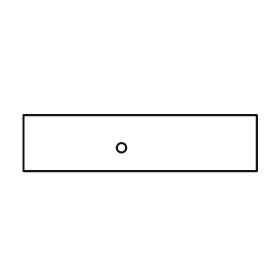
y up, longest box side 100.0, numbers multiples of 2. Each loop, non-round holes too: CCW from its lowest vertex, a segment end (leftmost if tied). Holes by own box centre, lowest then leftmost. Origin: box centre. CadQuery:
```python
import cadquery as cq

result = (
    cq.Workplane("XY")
    .moveTo(-50.0, -12.0)
    .lineTo(50.0, -12.0)
    .lineTo(50.0, 12.0)
    .lineTo(-50.0, 12.0)
    .close()
    .moveTo(-8.0, -2.0)
    .circle(2.0)
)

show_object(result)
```